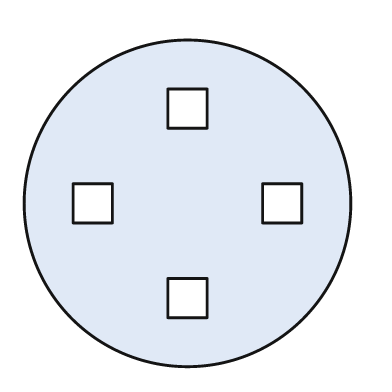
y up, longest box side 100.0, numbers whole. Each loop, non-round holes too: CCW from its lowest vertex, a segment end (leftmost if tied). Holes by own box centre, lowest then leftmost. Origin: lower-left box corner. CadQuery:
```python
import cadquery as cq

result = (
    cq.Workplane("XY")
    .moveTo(50.0, 50.0)
    .circle(50.0)
    .moveTo(44.0, 15.0)
    .lineTo(56.0, 15.0)
    .lineTo(56.0, 27.0)
    .lineTo(44.0, 27.0)
    .close()
    .moveTo(15.0, 44.0)
    .lineTo(27.0, 44.0)
    .lineTo(27.0, 56.0)
    .lineTo(15.0, 56.0)
    .close()
    .moveTo(73.0, 44.0)
    .lineTo(85.0, 44.0)
    .lineTo(85.0, 56.0)
    .lineTo(73.0, 56.0)
    .close()
    .moveTo(44.0, 73.0)
    .lineTo(56.0, 73.0)
    .lineTo(56.0, 85.0)
    .lineTo(44.0, 85.0)
    .close()
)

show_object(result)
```